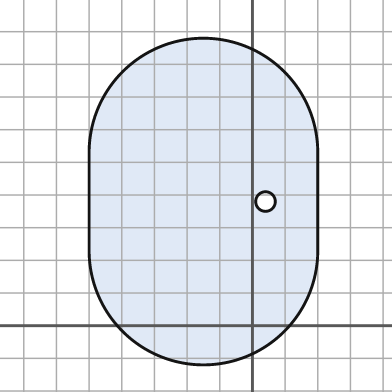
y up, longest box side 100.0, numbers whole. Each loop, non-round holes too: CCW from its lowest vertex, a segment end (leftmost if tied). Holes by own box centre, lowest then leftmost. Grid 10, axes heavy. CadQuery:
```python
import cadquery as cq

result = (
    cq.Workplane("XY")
    .moveTo(-50.0, 23.0)
    .threePointArc((-15.0, -12.0), (20.0, 23.0))
    .lineTo(20.0, 53.0)
    .threePointArc((-15.0, 88.0), (-50.0, 53.0))
    .close()
    .moveTo(4.0, 38.0)
    .circle(3.0)
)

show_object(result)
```